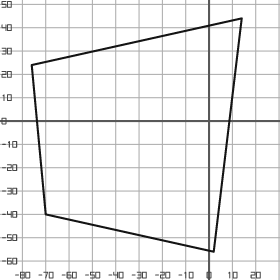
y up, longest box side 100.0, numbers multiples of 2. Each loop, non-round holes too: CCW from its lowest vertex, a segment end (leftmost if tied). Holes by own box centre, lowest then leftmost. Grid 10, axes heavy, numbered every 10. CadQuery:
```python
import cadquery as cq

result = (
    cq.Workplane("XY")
    .moveTo(2.0, -56.0)
    .lineTo(14.0, 44.0)
    .lineTo(-76.0, 24.0)
    .lineTo(-70.0, -40.0)
    .close()
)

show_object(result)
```